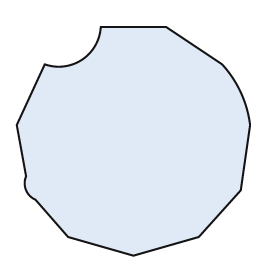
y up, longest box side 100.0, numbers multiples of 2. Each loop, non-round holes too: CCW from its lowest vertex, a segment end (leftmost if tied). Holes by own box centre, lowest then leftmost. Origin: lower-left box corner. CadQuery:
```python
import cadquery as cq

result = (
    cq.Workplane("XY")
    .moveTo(50.0, 0.0)
    .lineTo(78.0, 8.0)
    .lineTo(96.0, 28.0)
    .lineTo(100.0, 56.0)
    .threePointArc((96.0, 70.0), (88.0, 82.0))
    .lineTo(64.0, 98.0)
    .lineTo(36.0, 98.0)
    .threePointArc((28.0, 84.0), (12.0, 82.0))
    .lineTo(0.0, 56.0)
    .lineTo(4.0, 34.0)
    .threePointArc((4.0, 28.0), (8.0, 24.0))
    .lineTo(22.0, 8.0)
    .close()
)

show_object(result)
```